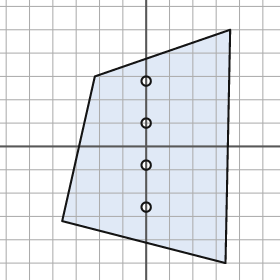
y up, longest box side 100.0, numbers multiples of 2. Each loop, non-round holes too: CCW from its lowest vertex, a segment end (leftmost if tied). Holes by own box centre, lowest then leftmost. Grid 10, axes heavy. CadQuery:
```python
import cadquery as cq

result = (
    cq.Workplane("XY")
    .moveTo(34.0, -50.0)
    .lineTo(36.0, 50.0)
    .lineTo(-22.0, 30.0)
    .lineTo(-36.0, -32.0)
    .close()
    .moveTo(0.0, -26.0)
    .circle(2.0)
    .moveTo(0.0, -8.0)
    .circle(2.0)
    .moveTo(0.0, 10.0)
    .circle(2.0)
    .moveTo(0.0, 28.0)
    .circle(2.0)
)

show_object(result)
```